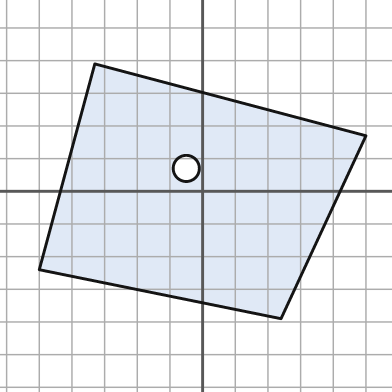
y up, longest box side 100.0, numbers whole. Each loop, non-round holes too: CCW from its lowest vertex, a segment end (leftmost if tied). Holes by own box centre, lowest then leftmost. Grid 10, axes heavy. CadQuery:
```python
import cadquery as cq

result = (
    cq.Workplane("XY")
    .moveTo(24.0, -39.0)
    .lineTo(50.0, 17.0)
    .lineTo(-33.0, 39.0)
    .lineTo(-50.0, -24.0)
    .close()
    .moveTo(-5.0, 7.0)
    .circle(4.0)
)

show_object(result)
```